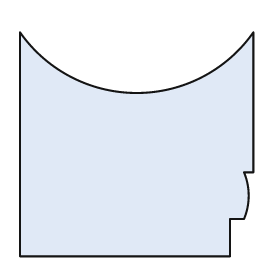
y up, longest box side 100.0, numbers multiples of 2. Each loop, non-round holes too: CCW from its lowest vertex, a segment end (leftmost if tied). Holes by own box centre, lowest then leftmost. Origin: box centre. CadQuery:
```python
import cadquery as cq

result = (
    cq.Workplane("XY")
    .moveTo(-50.0, -48.0)
    .lineTo(40.0, -48.0)
    .lineTo(40.0, -32.0)
    .lineTo(46.0, -32.0)
    .threePointArc((48.0, -22.0), (46.0, -12.0))
    .lineTo(50.0, -12.0)
    .lineTo(50.0, 48.0)
    .threePointArc((0.0, 22.0), (-50.0, 48.0))
    .close()
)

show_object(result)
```